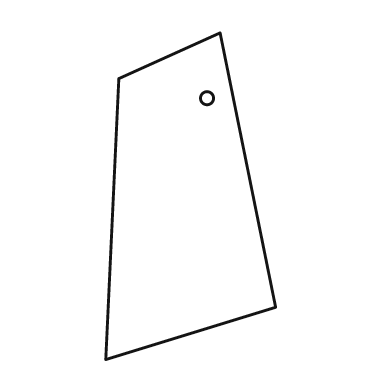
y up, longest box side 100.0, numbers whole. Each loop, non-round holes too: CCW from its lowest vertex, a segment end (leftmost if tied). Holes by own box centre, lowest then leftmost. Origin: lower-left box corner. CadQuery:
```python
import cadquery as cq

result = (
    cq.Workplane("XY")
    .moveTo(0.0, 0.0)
    .lineTo(52.0, 16.0)
    .lineTo(35.0, 100.0)
    .lineTo(4.0, 86.0)
    .close()
    .moveTo(31.0, 80.0)
    .circle(2.0)
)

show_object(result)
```